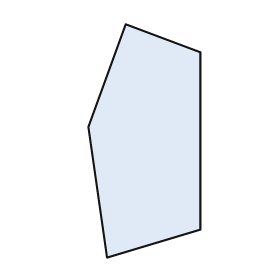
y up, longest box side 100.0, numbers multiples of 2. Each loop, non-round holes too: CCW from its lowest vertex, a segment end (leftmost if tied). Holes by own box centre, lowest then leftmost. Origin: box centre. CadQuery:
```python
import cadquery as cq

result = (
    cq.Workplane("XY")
    .moveTo(-16.0, -50.0)
    .lineTo(24.0, -38.0)
    .lineTo(24.0, 38.0)
    .lineTo(-8.0, 50.0)
    .lineTo(-24.0, 6.0)
    .close()
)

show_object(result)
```